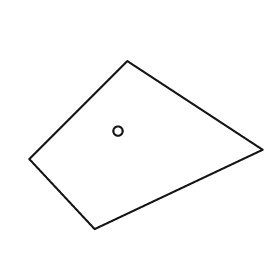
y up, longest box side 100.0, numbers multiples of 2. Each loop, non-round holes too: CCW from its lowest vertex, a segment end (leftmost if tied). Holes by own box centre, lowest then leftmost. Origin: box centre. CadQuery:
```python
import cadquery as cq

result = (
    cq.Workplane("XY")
    .moveTo(-22.0, -36.0)
    .lineTo(50.0, -2.0)
    .lineTo(-8.0, 36.0)
    .lineTo(-50.0, -6.0)
    .close()
    .moveTo(-12.0, 6.0)
    .circle(2.0)
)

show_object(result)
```